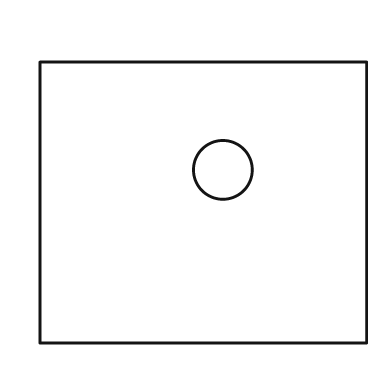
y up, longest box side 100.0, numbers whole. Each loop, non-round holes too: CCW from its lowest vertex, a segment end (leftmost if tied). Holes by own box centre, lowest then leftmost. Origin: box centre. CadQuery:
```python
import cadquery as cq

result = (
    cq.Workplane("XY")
    .moveTo(-50.0, -43.0)
    .lineTo(50.0, -43.0)
    .lineTo(50.0, 43.0)
    .lineTo(-50.0, 43.0)
    .close()
    .moveTo(6.0, 10.0)
    .circle(9.0)
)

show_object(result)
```